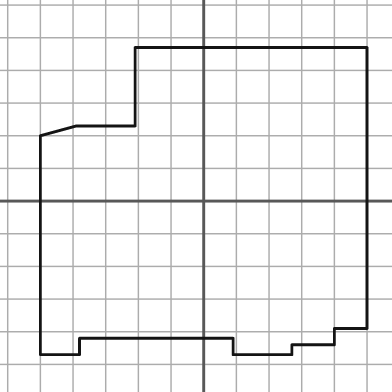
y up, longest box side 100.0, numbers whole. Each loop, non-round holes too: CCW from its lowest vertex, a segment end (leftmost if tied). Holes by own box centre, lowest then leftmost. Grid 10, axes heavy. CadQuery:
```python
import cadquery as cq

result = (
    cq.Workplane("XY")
    .moveTo(-50.0, -47.0)
    .lineTo(-38.0, -47.0)
    .lineTo(-38.0, -42.0)
    .lineTo(9.0, -42.0)
    .lineTo(9.0, -47.0)
    .lineTo(27.0, -47.0)
    .lineTo(27.0, -44.0)
    .lineTo(40.0, -44.0)
    .lineTo(40.0, -39.0)
    .lineTo(50.0, -39.0)
    .lineTo(50.0, 47.0)
    .lineTo(-21.0, 47.0)
    .lineTo(-21.0, 23.0)
    .lineTo(-39.0, 23.0)
    .lineTo(-50.0, 20.0)
    .close()
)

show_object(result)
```